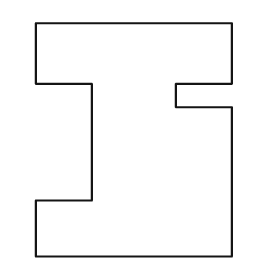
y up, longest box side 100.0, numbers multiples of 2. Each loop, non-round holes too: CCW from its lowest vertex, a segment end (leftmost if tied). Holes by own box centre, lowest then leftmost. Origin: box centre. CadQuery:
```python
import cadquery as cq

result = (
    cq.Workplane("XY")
    .moveTo(-42.0, -50.0)
    .lineTo(42.0, -50.0)
    .lineTo(42.0, 14.0)
    .lineTo(18.0, 14.0)
    .lineTo(18.0, 24.0)
    .lineTo(42.0, 24.0)
    .lineTo(42.0, 50.0)
    .lineTo(-42.0, 50.0)
    .lineTo(-42.0, 24.0)
    .lineTo(-18.0, 24.0)
    .lineTo(-18.0, -26.0)
    .lineTo(-42.0, -26.0)
    .close()
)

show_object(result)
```